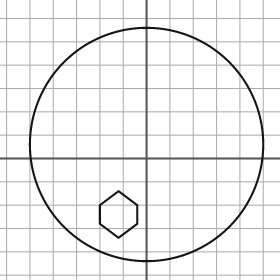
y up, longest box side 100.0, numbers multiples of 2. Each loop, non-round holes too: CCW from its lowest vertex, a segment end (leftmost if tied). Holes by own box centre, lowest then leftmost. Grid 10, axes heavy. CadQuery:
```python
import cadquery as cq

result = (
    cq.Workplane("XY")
    .moveTo(0.0, 6.0)
    .circle(50.0)
    .moveTo(-12.0, -34.0)
    .lineTo(-4.0, -28.0)
    .lineTo(-4.0, -20.0)
    .lineTo(-12.0, -14.0)
    .lineTo(-20.0, -20.0)
    .lineTo(-20.0, -28.0)
    .close()
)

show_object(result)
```